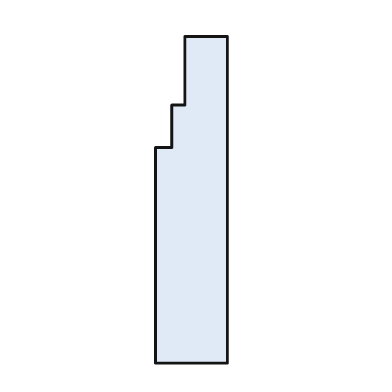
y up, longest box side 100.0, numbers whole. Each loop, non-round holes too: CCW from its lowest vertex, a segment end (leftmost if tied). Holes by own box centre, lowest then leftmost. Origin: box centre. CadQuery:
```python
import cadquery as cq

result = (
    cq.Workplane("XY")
    .moveTo(-11.0, -50.0)
    .lineTo(11.0, -50.0)
    .lineTo(11.0, 50.0)
    .lineTo(-2.0, 50.0)
    .lineTo(-2.0, 29.0)
    .lineTo(-6.0, 29.0)
    .lineTo(-6.0, 16.0)
    .lineTo(-11.0, 16.0)
    .close()
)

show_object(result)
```